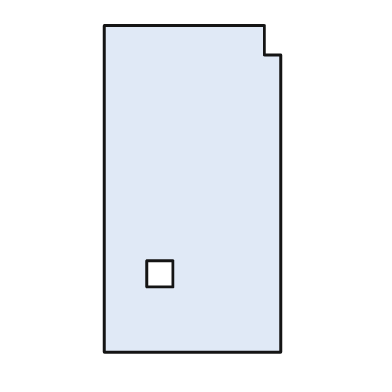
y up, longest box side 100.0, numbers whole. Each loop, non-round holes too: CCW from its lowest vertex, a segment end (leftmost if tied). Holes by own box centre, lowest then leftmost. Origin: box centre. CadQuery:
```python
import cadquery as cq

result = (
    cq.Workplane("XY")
    .moveTo(-27.0, -50.0)
    .lineTo(27.0, -50.0)
    .lineTo(27.0, 41.0)
    .lineTo(22.0, 41.0)
    .lineTo(22.0, 50.0)
    .lineTo(-27.0, 50.0)
    .close()
    .moveTo(-14.0, -30.0)
    .lineTo(-6.0, -30.0)
    .lineTo(-6.0, -22.0)
    .lineTo(-14.0, -22.0)
    .close()
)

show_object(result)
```